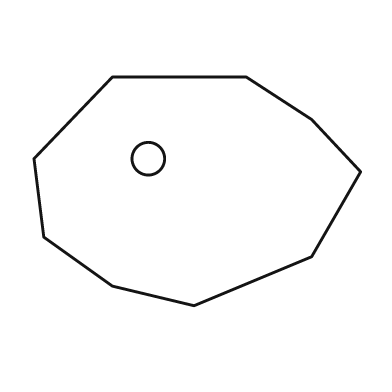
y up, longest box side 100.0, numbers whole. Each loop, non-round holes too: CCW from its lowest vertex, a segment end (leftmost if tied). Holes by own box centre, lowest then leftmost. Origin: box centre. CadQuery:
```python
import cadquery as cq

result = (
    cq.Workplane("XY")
    .moveTo(-1.0, -35.0)
    .lineTo(35.0, -20.0)
    .lineTo(50.0, 6.0)
    .lineTo(35.0, 22.0)
    .lineTo(15.0, 35.0)
    .lineTo(-26.0, 35.0)
    .lineTo(-50.0, 10.0)
    .lineTo(-47.0, -14.0)
    .lineTo(-26.0, -29.0)
    .close()
    .moveTo(-15.0, 10.0)
    .circle(5.0)
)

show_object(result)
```